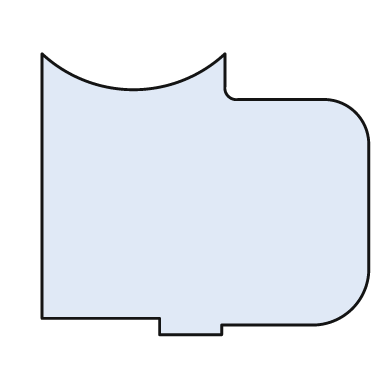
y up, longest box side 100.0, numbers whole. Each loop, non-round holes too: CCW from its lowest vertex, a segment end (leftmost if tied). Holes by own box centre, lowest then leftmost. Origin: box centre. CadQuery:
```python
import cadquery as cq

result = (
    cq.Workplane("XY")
    .moveTo(-14.0, -43.0)
    .lineTo(5.0, -43.0)
    .lineTo(5.0, -40.0)
    .lineTo(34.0, -40.0)
    .threePointArc((45.0, -35.0), (50.0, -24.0))
    .lineTo(50.0, 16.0)
    .threePointArc((46.0, 25.0), (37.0, 29.0))
    .lineTo(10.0, 29.0)
    .threePointArc((7.0, 30.0), (6.0, 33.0))
    .lineTo(6.0, 43.0)
    .threePointArc((-22.0, 32.0), (-50.0, 43.0))
    .lineTo(-50.0, -38.0)
    .lineTo(-14.0, -38.0)
    .close()
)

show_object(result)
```